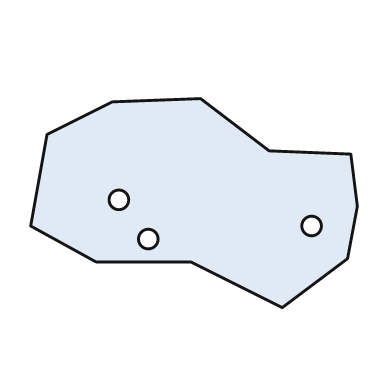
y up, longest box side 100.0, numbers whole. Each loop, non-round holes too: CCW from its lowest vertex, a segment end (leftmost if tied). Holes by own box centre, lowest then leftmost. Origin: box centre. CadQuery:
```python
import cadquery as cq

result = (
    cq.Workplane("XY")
    .moveTo(27.0, -32.0)
    .lineTo(47.0, -17.0)
    .lineTo(50.0, -1.0)
    .lineTo(48.0, 15.0)
    .lineTo(23.0, 16.0)
    .lineTo(2.0, 32.0)
    .lineTo(-25.0, 31.0)
    .lineTo(-45.0, 21.0)
    .lineTo(-50.0, -7.0)
    .lineTo(-30.0, -18.0)
    .lineTo(-1.0, -18.0)
    .close()
    .moveTo(-14.0, -11.0)
    .circle(3.0)
    .moveTo(36.0, -7.0)
    .circle(3.0)
    .moveTo(-23.0, 1.0)
    .circle(3.0)
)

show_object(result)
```